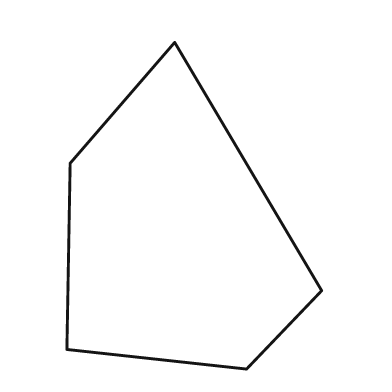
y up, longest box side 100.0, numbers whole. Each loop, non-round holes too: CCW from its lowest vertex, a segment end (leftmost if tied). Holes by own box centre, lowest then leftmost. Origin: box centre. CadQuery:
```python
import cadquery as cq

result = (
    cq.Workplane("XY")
    .moveTo(16.0, -50.0)
    .lineTo(39.0, -26.0)
    .lineTo(-6.0, 50.0)
    .lineTo(-38.0, 13.0)
    .lineTo(-39.0, -44.0)
    .close()
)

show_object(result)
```